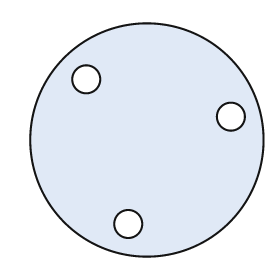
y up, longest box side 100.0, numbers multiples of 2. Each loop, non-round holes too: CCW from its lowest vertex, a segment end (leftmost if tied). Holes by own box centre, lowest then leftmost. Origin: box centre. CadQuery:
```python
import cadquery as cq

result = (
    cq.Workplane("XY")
    .moveTo(0.0, 0.0)
    .circle(50.0)
    .moveTo(-8.0, -36.0)
    .circle(6.0)
    .moveTo(36.0, 10.0)
    .circle(6.0)
    .moveTo(-26.0, 26.0)
    .circle(6.0)
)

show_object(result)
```